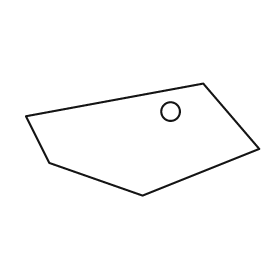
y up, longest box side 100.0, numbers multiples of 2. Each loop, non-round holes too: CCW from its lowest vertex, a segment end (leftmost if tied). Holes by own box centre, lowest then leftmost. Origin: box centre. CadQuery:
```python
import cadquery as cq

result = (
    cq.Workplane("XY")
    .moveTo(0.0, -24.0)
    .lineTo(50.0, -4.0)
    .lineTo(26.0, 24.0)
    .lineTo(-50.0, 10.0)
    .lineTo(-40.0, -10.0)
    .close()
    .moveTo(12.0, 12.0)
    .circle(4.0)
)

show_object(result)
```